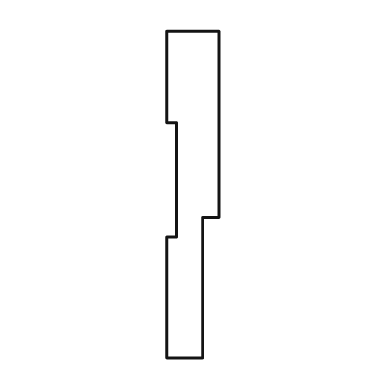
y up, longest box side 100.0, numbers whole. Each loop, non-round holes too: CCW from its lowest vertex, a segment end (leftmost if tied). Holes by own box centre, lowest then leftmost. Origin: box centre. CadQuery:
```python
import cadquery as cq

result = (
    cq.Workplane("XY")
    .moveTo(-8.0, -50.0)
    .lineTo(3.0, -50.0)
    .lineTo(3.0, -7.0)
    .lineTo(8.0, -7.0)
    .lineTo(8.0, 50.0)
    .lineTo(-8.0, 50.0)
    .lineTo(-8.0, 22.0)
    .lineTo(-5.0, 22.0)
    .lineTo(-5.0, -13.0)
    .lineTo(-8.0, -13.0)
    .close()
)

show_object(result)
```